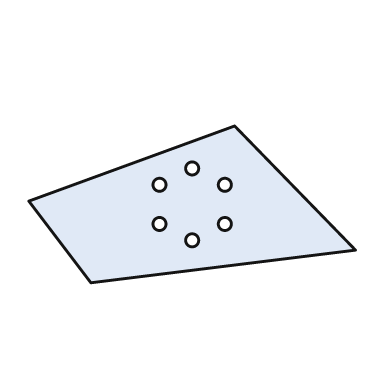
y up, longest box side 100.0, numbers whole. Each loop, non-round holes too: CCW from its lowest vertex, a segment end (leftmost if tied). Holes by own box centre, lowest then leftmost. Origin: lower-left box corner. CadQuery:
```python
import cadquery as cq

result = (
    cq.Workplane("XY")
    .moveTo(19.0, 0.0)
    .lineTo(100.0, 10.0)
    .lineTo(63.0, 48.0)
    .lineTo(0.0, 25.0)
    .close()
    .moveTo(50.0, 13.0)
    .circle(2.0)
    .moveTo(40.0, 18.0)
    .circle(2.0)
    .moveTo(60.0, 18.0)
    .circle(2.0)
    .moveTo(40.0, 30.0)
    .circle(2.0)
    .moveTo(60.0, 30.0)
    .circle(2.0)
    .moveTo(50.0, 35.0)
    .circle(2.0)
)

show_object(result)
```